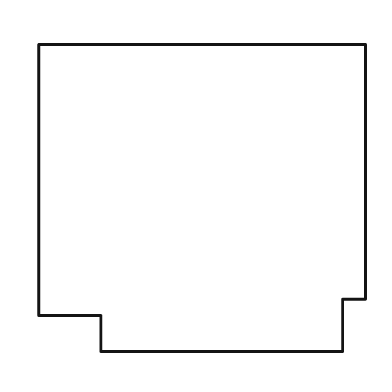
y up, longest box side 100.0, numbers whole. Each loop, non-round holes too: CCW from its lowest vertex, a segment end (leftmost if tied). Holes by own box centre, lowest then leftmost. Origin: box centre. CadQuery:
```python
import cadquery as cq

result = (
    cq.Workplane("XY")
    .moveTo(-31.0, -47.0)
    .lineTo(43.0, -47.0)
    .lineTo(43.0, -31.0)
    .lineTo(50.0, -31.0)
    .lineTo(50.0, 47.0)
    .lineTo(-50.0, 47.0)
    .lineTo(-50.0, -36.0)
    .lineTo(-31.0, -36.0)
    .close()
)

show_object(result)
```